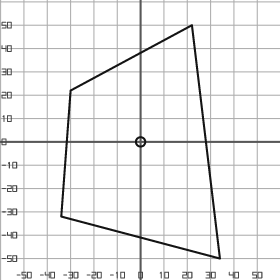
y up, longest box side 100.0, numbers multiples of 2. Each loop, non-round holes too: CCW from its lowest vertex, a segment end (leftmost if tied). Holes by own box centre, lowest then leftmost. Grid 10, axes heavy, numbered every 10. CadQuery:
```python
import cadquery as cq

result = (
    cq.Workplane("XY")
    .moveTo(34.0, -50.0)
    .lineTo(22.0, 50.0)
    .lineTo(-30.0, 22.0)
    .lineTo(-34.0, -32.0)
    .close()
    .moveTo(0.0, 0.0)
    .circle(2.0)
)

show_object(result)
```